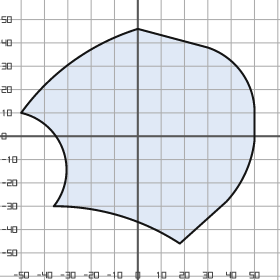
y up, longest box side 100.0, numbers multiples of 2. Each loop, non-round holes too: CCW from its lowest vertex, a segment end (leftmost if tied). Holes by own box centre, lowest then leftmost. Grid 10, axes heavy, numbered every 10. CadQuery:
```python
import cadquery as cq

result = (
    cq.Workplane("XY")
    .moveTo(18.0, -46.0)
    .lineTo(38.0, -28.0)
    .threePointArc((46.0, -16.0), (50.0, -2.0))
    .lineTo(50.0, 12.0)
    .threePointArc((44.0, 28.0), (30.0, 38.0))
    .lineTo(0.0, 46.0)
    .threePointArc((-28.0, 32.0), (-50.0, 10.0))
    .threePointArc((-32.0, -6.0), (-36.0, -30.0))
    .threePointArc((-8.0, -34.0), (18.0, -46.0))
    .close()
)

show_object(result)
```